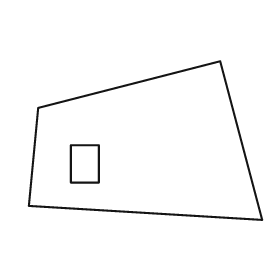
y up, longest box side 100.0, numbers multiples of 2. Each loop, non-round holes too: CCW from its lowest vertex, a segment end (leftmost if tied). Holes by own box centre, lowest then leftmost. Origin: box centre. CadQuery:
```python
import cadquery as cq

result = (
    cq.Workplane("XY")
    .moveTo(50.0, -34.0)
    .lineTo(32.0, 34.0)
    .lineTo(-46.0, 14.0)
    .lineTo(-50.0, -28.0)
    .close()
    .moveTo(-32.0, -18.0)
    .lineTo(-20.0, -18.0)
    .lineTo(-20.0, -2.0)
    .lineTo(-32.0, -2.0)
    .close()
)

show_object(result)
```